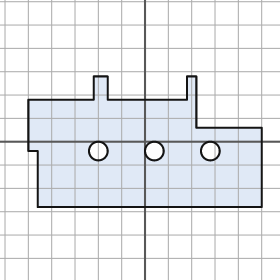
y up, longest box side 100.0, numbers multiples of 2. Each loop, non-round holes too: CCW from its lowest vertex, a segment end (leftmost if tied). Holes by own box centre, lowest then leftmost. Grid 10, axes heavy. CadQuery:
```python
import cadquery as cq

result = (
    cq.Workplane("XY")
    .moveTo(-46.0, -28.0)
    .lineTo(50.0, -28.0)
    .lineTo(50.0, 6.0)
    .lineTo(22.0, 6.0)
    .lineTo(22.0, 28.0)
    .lineTo(18.0, 28.0)
    .lineTo(18.0, 18.0)
    .lineTo(-16.0, 18.0)
    .lineTo(-16.0, 28.0)
    .lineTo(-22.0, 28.0)
    .lineTo(-22.0, 18.0)
    .lineTo(-50.0, 18.0)
    .lineTo(-50.0, -4.0)
    .lineTo(-46.0, -4.0)
    .close()
    .moveTo(-20.0, -4.0)
    .circle(4.0)
    .moveTo(4.0, -4.0)
    .circle(4.0)
    .moveTo(28.0, -4.0)
    .circle(4.0)
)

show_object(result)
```